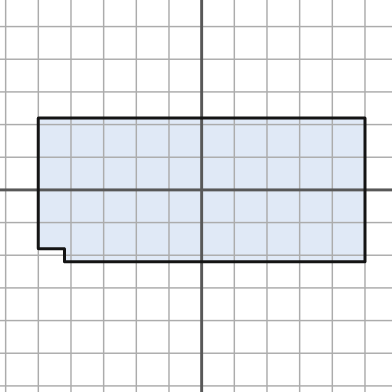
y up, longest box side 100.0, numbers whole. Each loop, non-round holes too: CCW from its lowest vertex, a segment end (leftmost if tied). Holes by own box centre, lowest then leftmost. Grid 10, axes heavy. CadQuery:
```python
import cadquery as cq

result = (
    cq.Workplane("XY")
    .moveTo(-42.0, -22.0)
    .lineTo(50.0, -22.0)
    .lineTo(50.0, 22.0)
    .lineTo(-50.0, 22.0)
    .lineTo(-50.0, -18.0)
    .lineTo(-42.0, -18.0)
    .close()
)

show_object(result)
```